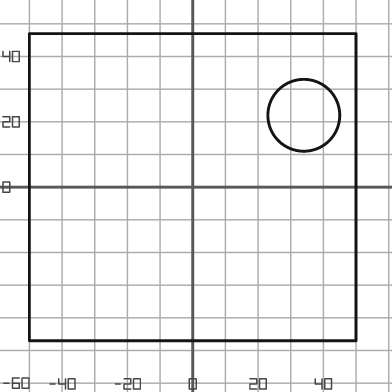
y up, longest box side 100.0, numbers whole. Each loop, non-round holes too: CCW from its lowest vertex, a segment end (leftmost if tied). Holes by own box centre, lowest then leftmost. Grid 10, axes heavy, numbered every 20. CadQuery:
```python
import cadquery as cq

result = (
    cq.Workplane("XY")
    .moveTo(-50.0, -47.0)
    .lineTo(50.0, -47.0)
    .lineTo(50.0, 47.0)
    .lineTo(-50.0, 47.0)
    .close()
    .moveTo(34.0, 22.0)
    .circle(11.0)
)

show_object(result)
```